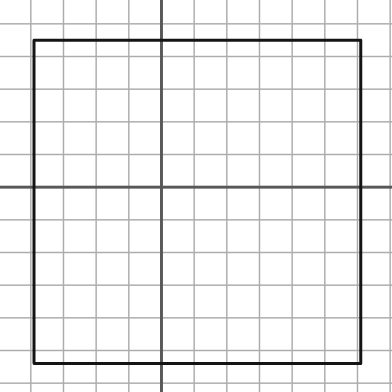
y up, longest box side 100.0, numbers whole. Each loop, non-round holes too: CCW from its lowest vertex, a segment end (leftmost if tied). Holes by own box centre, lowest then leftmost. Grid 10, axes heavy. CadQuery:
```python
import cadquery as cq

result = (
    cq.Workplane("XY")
    .moveTo(-39.0, -54.0)
    .lineTo(61.0, -54.0)
    .lineTo(61.0, 45.0)
    .lineTo(-39.0, 45.0)
    .close()
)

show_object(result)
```